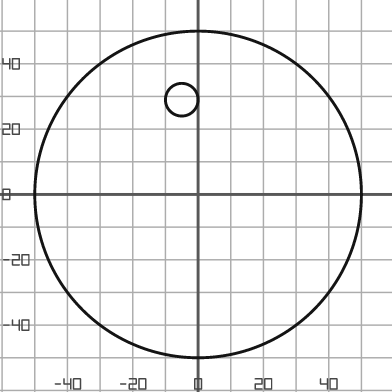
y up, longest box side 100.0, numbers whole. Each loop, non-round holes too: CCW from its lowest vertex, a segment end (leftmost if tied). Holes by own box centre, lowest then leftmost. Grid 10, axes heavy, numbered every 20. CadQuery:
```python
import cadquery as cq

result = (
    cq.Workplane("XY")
    .moveTo(0.0, 0.0)
    .circle(50.0)
    .moveTo(-5.0, 29.0)
    .circle(5.0)
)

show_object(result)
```